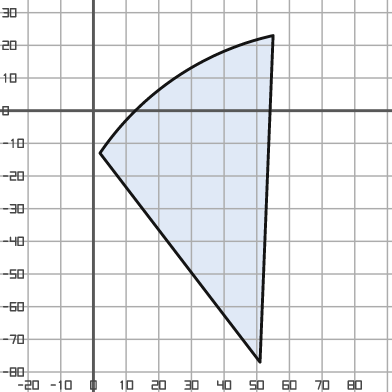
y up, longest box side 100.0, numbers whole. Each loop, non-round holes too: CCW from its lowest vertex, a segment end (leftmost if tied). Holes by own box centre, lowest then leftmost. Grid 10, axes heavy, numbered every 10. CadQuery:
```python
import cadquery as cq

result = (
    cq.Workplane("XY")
    .moveTo(51.0, -77.0)
    .lineTo(55.0, 23.0)
    .threePointArc((25.0, 10.0), (2.0, -13.0))
    .close()
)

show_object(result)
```